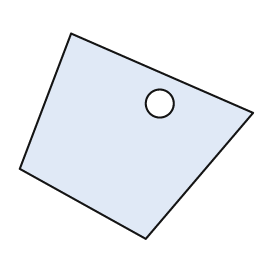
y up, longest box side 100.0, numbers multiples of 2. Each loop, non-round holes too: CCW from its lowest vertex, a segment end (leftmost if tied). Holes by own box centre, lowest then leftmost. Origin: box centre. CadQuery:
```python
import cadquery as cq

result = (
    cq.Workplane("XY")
    .moveTo(4.0, -44.0)
    .lineTo(50.0, 10.0)
    .lineTo(-28.0, 44.0)
    .lineTo(-50.0, -14.0)
    .close()
    .moveTo(10.0, 14.0)
    .circle(6.0)
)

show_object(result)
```